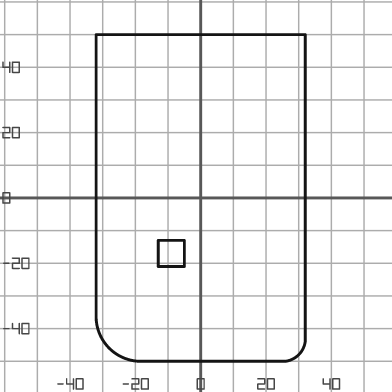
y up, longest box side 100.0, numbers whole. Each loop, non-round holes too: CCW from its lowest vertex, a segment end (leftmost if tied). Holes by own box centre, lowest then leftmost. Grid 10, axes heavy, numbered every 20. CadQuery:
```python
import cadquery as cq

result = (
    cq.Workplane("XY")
    .moveTo(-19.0, -50.0)
    .lineTo(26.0, -50.0)
    .threePointArc((30.0, -48.0), (32.0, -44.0))
    .lineTo(32.0, 50.0)
    .lineTo(-32.0, 50.0)
    .lineTo(-32.0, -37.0)
    .threePointArc((-28.0, -46.0), (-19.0, -50.0))
    .close()
    .moveTo(-13.0, -21.0)
    .lineTo(-5.0, -21.0)
    .lineTo(-5.0, -13.0)
    .lineTo(-13.0, -13.0)
    .close()
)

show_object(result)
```